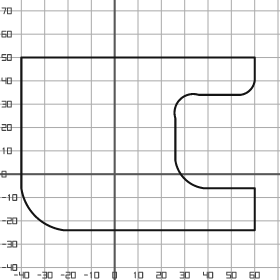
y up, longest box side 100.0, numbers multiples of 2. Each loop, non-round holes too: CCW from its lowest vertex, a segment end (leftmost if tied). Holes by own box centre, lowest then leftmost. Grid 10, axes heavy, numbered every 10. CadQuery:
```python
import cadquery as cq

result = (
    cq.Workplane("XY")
    .moveTo(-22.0, -24.0)
    .lineTo(60.0, -24.0)
    .lineTo(60.0, -6.0)
    .lineTo(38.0, -6.0)
    .threePointArc((30.0, -2.0), (26.0, 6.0))
    .lineTo(26.0, 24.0)
    .threePointArc((28.0, 32.0), (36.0, 34.0))
    .lineTo(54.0, 34.0)
    .threePointArc((58.0, 36.0), (60.0, 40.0))
    .lineTo(60.0, 50.0)
    .lineTo(-40.0, 50.0)
    .lineTo(-40.0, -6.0)
    .threePointArc((-34.0, -18.0), (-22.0, -24.0))
    .close()
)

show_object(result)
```